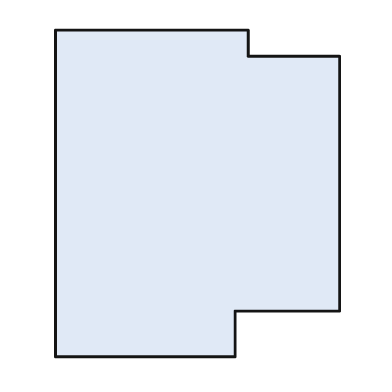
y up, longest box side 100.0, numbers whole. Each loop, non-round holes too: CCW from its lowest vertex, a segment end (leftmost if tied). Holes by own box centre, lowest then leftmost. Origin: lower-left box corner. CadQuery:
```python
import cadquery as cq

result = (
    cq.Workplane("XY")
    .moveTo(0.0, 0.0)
    .lineTo(55.0, 0.0)
    .lineTo(55.0, 14.0)
    .lineTo(87.0, 14.0)
    .lineTo(87.0, 92.0)
    .lineTo(59.0, 92.0)
    .lineTo(59.0, 100.0)
    .lineTo(0.0, 100.0)
    .close()
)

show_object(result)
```